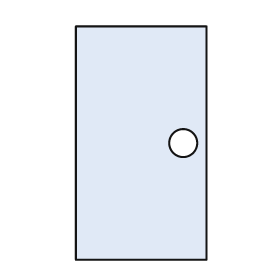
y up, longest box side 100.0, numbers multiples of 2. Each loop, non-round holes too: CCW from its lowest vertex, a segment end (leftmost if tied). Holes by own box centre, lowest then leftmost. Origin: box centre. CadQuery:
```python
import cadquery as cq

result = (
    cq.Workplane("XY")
    .moveTo(-28.0, -50.0)
    .lineTo(28.0, -50.0)
    .lineTo(28.0, 50.0)
    .lineTo(-28.0, 50.0)
    .close()
    .moveTo(18.0, 0.0)
    .circle(6.0)
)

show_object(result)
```